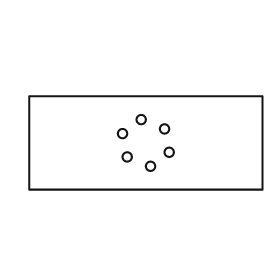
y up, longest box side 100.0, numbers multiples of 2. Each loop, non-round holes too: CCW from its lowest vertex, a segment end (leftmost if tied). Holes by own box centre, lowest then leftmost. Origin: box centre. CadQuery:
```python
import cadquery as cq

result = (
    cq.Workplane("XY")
    .moveTo(-50.0, -20.0)
    .lineTo(50.0, -20.0)
    .lineTo(50.0, 20.0)
    .lineTo(-50.0, 20.0)
    .close()
    .moveTo(2.0, -10.0)
    .circle(2.0)
    .moveTo(-8.0, -6.0)
    .circle(2.0)
    .moveTo(10.0, -4.0)
    .circle(2.0)
    .moveTo(-10.0, 4.0)
    .circle(2.0)
    .moveTo(8.0, 6.0)
    .circle(2.0)
    .moveTo(-2.0, 10.0)
    .circle(2.0)
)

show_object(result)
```